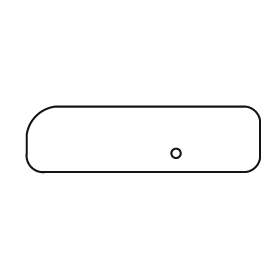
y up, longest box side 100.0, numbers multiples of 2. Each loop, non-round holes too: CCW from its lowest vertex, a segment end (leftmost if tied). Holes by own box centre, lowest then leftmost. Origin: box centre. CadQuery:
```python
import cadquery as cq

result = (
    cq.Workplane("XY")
    .moveTo(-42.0, -14.0)
    .lineTo(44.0, -14.0)
    .threePointArc((48.0, -12.0), (50.0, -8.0))
    .lineTo(50.0, 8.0)
    .threePointArc((48.0, 12.0), (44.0, 14.0))
    .lineTo(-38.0, 14.0)
    .threePointArc((-46.0, 10.0), (-50.0, 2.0))
    .lineTo(-50.0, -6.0)
    .threePointArc((-48.0, -12.0), (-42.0, -14.0))
    .close()
    .moveTo(14.0, -6.0)
    .circle(2.0)
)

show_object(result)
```